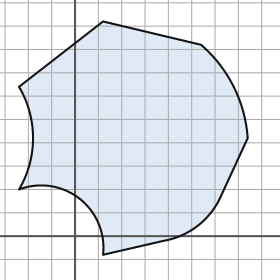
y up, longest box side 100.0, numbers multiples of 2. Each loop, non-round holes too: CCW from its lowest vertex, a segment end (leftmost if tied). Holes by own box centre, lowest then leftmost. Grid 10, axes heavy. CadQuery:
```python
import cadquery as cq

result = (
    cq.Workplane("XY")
    .moveTo(12.0, -8.0)
    .lineTo(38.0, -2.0)
    .threePointArc((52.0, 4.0), (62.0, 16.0))
    .lineTo(74.0, 42.0)
    .threePointArc((68.0, 64.0), (54.0, 82.0))
    .lineTo(12.0, 92.0)
    .lineTo(-24.0, 64.0)
    .threePointArc((-18.0, 42.0), (-24.0, 20.0))
    .threePointArc((2.0, 16.0), (12.0, -8.0))
    .close()
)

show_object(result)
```